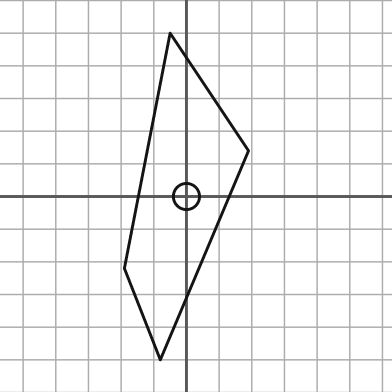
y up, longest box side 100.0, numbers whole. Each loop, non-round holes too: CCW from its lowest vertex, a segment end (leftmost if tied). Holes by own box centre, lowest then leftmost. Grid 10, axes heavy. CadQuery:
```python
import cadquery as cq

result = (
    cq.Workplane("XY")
    .moveTo(-8.0, -50.0)
    .lineTo(19.0, 14.0)
    .lineTo(-5.0, 50.0)
    .lineTo(-19.0, -22.0)
    .close()
    .moveTo(0.0, 0.0)
    .circle(4.0)
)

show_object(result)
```